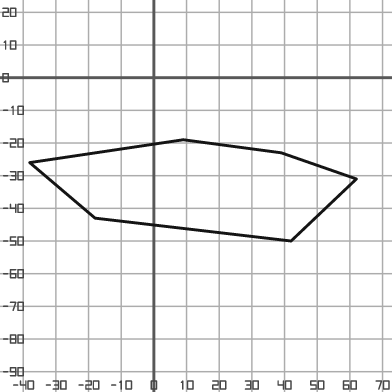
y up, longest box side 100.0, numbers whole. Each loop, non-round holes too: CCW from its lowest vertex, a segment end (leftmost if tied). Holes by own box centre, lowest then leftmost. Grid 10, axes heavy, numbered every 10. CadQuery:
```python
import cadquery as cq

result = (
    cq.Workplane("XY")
    .moveTo(42.0, -50.0)
    .lineTo(62.0, -31.0)
    .lineTo(39.0, -23.0)
    .lineTo(9.0, -19.0)
    .lineTo(-38.0, -26.0)
    .lineTo(-18.0, -43.0)
    .close()
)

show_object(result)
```